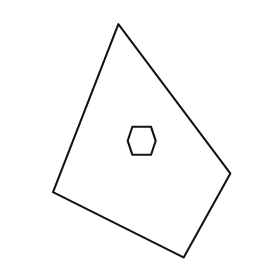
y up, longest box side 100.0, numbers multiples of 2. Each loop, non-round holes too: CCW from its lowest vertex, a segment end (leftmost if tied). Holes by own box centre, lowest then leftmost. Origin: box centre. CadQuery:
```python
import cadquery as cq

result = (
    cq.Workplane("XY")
    .moveTo(18.0, -50.0)
    .lineTo(38.0, -14.0)
    .lineTo(-10.0, 50.0)
    .lineTo(-38.0, -22.0)
    .close()
    .moveTo(-4.0, -6.0)
    .lineTo(4.0, -6.0)
    .lineTo(6.0, 0.0)
    .lineTo(4.0, 6.0)
    .lineTo(-4.0, 6.0)
    .lineTo(-6.0, 0.0)
    .close()
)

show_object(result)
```